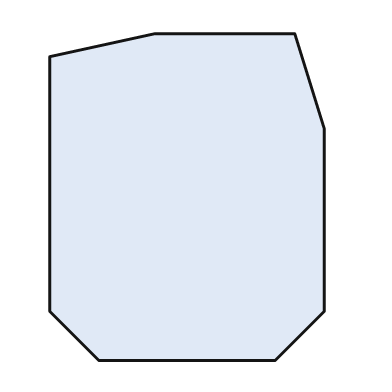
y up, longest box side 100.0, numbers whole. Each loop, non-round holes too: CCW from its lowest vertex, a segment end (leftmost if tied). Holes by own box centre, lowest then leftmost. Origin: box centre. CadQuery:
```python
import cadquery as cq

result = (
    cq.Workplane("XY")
    .moveTo(-27.0, -50.0)
    .lineTo(27.0, -50.0)
    .lineTo(42.0, -35.0)
    .lineTo(42.0, 21.0)
    .lineTo(33.0, 50.0)
    .lineTo(-10.0, 50.0)
    .lineTo(-42.0, 43.0)
    .lineTo(-42.0, -35.0)
    .close()
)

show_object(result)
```